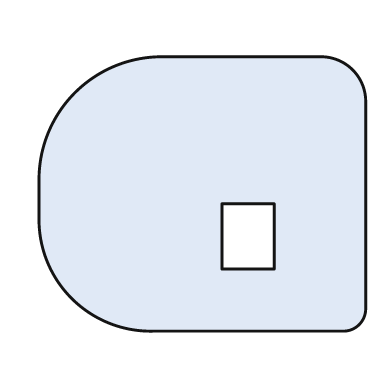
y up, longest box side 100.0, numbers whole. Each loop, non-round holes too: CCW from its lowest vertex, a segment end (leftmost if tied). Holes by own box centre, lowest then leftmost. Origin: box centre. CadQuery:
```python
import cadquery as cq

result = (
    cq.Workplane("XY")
    .moveTo(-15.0, -42.0)
    .lineTo(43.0, -42.0)
    .threePointArc((48.0, -40.0), (50.0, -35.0))
    .lineTo(50.0, 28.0)
    .threePointArc((46.0, 38.0), (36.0, 42.0))
    .lineTo(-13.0, 42.0)
    .threePointArc((-39.0, 31.0), (-50.0, 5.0))
    .lineTo(-50.0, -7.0)
    .threePointArc((-40.0, -32.0), (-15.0, -42.0))
    .close()
    .moveTo(6.0, -23.0)
    .lineTo(22.0, -23.0)
    .lineTo(22.0, -3.0)
    .lineTo(6.0, -3.0)
    .close()
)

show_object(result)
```